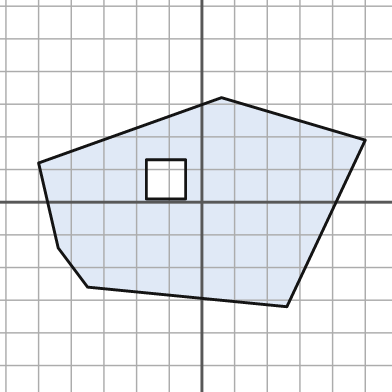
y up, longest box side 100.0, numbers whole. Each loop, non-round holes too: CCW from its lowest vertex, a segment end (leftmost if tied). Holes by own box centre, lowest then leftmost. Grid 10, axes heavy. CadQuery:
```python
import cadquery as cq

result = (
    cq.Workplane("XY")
    .moveTo(26.0, -32.0)
    .lineTo(50.0, 19.0)
    .lineTo(6.0, 32.0)
    .lineTo(-50.0, 12.0)
    .lineTo(-44.0, -14.0)
    .lineTo(-35.0, -26.0)
    .close()
    .moveTo(-17.0, 1.0)
    .lineTo(-5.0, 1.0)
    .lineTo(-5.0, 13.0)
    .lineTo(-17.0, 13.0)
    .close()
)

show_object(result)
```